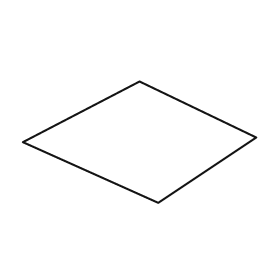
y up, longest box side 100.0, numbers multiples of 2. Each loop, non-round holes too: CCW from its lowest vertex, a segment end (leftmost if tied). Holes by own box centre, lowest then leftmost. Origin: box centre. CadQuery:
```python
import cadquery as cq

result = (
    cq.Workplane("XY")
    .moveTo(8.0, -26.0)
    .lineTo(50.0, 2.0)
    .lineTo(0.0, 26.0)
    .lineTo(-50.0, 0.0)
    .close()
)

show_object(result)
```